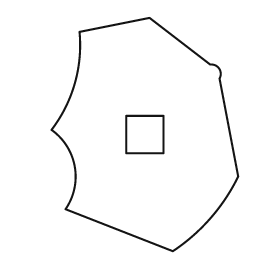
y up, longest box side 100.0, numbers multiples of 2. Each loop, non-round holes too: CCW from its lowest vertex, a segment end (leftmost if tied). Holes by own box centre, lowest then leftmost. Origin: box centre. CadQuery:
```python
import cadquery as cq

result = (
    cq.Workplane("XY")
    .moveTo(12.0, -50.0)
    .threePointArc((28.0, -36.0), (40.0, -18.0))
    .lineTo(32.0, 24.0)
    .threePointArc((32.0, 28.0), (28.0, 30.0))
    .lineTo(2.0, 50.0)
    .lineTo(-28.0, 44.0)
    .threePointArc((-30.0, 22.0), (-40.0, 2.0))
    .threePointArc((-30.0, -14.0), (-34.0, -32.0))
    .close()
    .moveTo(-8.0, -8.0)
    .lineTo(8.0, -8.0)
    .lineTo(8.0, 8.0)
    .lineTo(-8.0, 8.0)
    .close()
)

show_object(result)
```